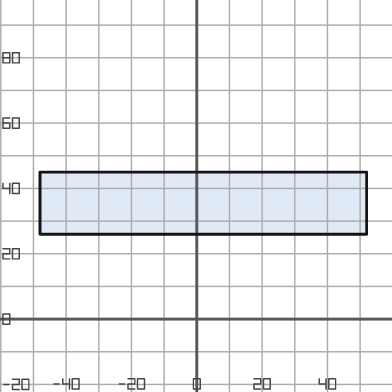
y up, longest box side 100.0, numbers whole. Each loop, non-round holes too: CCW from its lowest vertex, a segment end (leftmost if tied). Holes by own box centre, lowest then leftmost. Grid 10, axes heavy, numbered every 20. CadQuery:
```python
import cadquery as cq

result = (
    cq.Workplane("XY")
    .moveTo(-48.0, 26.0)
    .lineTo(52.0, 26.0)
    .lineTo(52.0, 45.0)
    .lineTo(-48.0, 45.0)
    .close()
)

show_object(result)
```